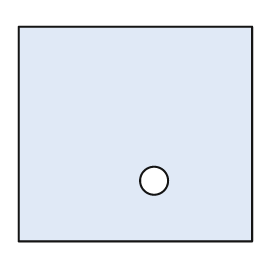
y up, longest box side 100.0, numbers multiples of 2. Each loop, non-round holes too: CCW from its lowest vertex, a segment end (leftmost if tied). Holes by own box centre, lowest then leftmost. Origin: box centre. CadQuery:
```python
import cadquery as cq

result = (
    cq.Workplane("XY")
    .moveTo(-50.0, -46.0)
    .lineTo(50.0, -46.0)
    .lineTo(50.0, 46.0)
    .lineTo(-50.0, 46.0)
    .close()
    .moveTo(8.0, -20.0)
    .circle(6.0)
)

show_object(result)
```